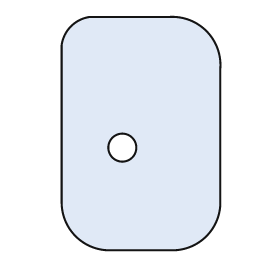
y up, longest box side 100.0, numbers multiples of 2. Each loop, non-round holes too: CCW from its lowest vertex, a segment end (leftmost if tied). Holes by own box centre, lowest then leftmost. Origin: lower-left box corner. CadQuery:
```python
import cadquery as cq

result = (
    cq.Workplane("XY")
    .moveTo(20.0, 0.0)
    .lineTo(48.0, 0.0)
    .threePointArc((62.0, 6.0), (68.0, 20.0))
    .lineTo(68.0, 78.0)
    .threePointArc((62.0, 94.0), (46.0, 100.0))
    .lineTo(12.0, 100.0)
    .threePointArc((4.0, 96.0), (0.0, 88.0))
    .lineTo(0.0, 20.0)
    .threePointArc((6.0, 6.0), (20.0, 0.0))
    .close()
    .moveTo(26.0, 44.0)
    .circle(6.0)
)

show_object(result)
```